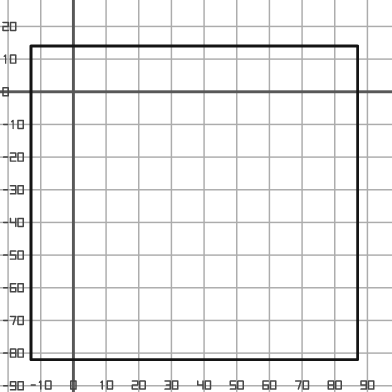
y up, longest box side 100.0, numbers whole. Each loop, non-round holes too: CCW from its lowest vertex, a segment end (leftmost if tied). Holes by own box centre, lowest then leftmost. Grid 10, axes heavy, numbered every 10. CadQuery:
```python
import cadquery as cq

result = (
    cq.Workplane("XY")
    .moveTo(-13.0, -82.0)
    .lineTo(87.0, -82.0)
    .lineTo(87.0, 14.0)
    .lineTo(-13.0, 14.0)
    .close()
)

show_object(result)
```